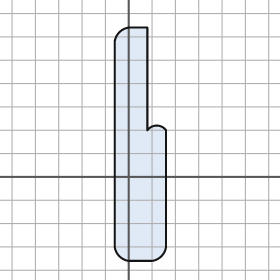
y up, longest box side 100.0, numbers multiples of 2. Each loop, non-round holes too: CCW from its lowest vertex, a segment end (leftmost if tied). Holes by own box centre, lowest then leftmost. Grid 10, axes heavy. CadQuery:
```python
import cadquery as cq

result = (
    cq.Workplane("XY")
    .moveTo(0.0, -36.0)
    .lineTo(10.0, -36.0)
    .threePointArc((14.0, -34.0), (16.0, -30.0))
    .lineTo(16.0, 20.0)
    .threePointArc((12.0, 22.0), (8.0, 20.0))
    .lineTo(8.0, 64.0)
    .lineTo(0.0, 64.0)
    .threePointArc((-4.0, 62.0), (-6.0, 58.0))
    .lineTo(-6.0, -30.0)
    .threePointArc((-4.0, -34.0), (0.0, -36.0))
    .close()
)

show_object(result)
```